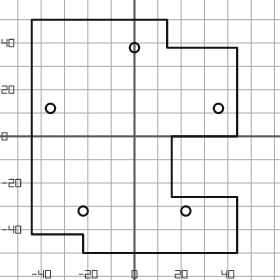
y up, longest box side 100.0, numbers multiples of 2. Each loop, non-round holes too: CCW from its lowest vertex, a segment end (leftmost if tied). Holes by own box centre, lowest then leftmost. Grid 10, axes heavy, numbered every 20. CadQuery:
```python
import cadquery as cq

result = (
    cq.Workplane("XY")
    .moveTo(-22.0, -50.0)
    .lineTo(44.0, -50.0)
    .lineTo(44.0, -26.0)
    .lineTo(16.0, -26.0)
    .lineTo(16.0, 0.0)
    .lineTo(44.0, 0.0)
    .lineTo(44.0, 38.0)
    .lineTo(14.0, 38.0)
    .lineTo(14.0, 50.0)
    .lineTo(-44.0, 50.0)
    .lineTo(-44.0, -42.0)
    .lineTo(-22.0, -42.0)
    .close()
    .moveTo(-22.0, -32.0)
    .circle(2.0)
    .moveTo(22.0, -32.0)
    .circle(2.0)
    .moveTo(-36.0, 12.0)
    .circle(2.0)
    .moveTo(36.0, 12.0)
    .circle(2.0)
    .moveTo(0.0, 38.0)
    .circle(2.0)
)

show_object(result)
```